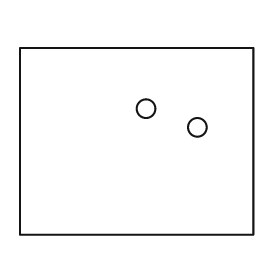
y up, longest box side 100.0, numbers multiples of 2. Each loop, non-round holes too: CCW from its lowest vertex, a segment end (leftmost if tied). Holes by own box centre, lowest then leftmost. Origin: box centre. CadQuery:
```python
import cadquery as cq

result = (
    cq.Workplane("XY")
    .moveTo(-50.0, -40.0)
    .lineTo(50.0, -40.0)
    .lineTo(50.0, 40.0)
    .lineTo(-50.0, 40.0)
    .close()
    .moveTo(26.0, 6.0)
    .circle(4.0)
    .moveTo(4.0, 14.0)
    .circle(4.0)
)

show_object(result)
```